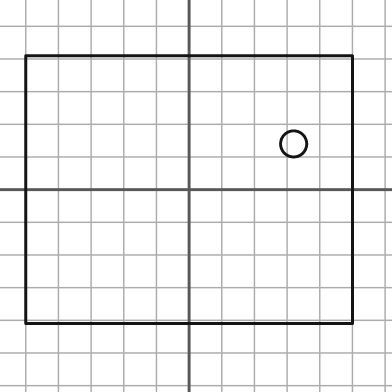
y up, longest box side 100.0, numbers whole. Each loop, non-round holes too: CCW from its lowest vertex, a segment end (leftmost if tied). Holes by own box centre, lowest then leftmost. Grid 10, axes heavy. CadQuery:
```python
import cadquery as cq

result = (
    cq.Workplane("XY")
    .moveTo(-50.0, -41.0)
    .lineTo(50.0, -41.0)
    .lineTo(50.0, 41.0)
    .lineTo(-50.0, 41.0)
    .close()
    .moveTo(32.0, 14.0)
    .circle(4.0)
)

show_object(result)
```